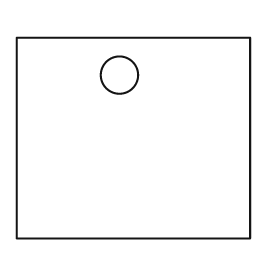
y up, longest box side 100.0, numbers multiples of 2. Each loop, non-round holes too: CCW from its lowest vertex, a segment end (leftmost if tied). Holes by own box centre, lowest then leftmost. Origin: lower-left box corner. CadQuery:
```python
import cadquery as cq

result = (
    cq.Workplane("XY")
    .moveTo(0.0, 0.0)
    .lineTo(100.0, 0.0)
    .lineTo(100.0, 86.0)
    .lineTo(0.0, 86.0)
    .close()
    .moveTo(44.0, 70.0)
    .circle(8.0)
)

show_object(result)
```